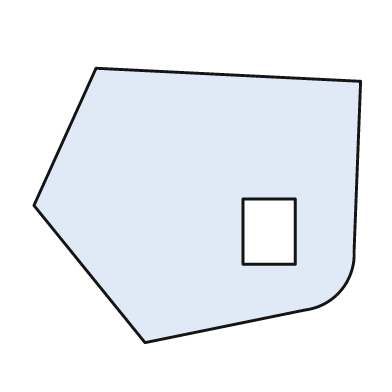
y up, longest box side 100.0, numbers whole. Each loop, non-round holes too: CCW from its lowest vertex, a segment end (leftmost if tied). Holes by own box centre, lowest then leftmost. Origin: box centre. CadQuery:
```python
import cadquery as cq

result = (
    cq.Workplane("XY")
    .moveTo(-16.0, -42.0)
    .lineTo(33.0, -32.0)
    .threePointArc((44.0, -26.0), (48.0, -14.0))
    .lineTo(50.0, 38.0)
    .lineTo(-31.0, 42.0)
    .lineTo(-50.0, 0.0)
    .close()
    .moveTo(14.0, -18.0)
    .lineTo(30.0, -18.0)
    .lineTo(30.0, 2.0)
    .lineTo(14.0, 2.0)
    .close()
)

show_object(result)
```